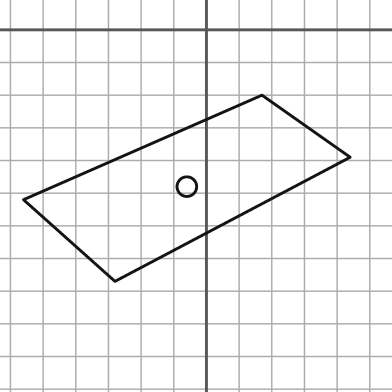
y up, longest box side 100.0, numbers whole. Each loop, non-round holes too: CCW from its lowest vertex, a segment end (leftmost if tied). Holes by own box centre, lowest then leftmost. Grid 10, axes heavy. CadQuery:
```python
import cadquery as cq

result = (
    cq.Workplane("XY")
    .moveTo(-28.0, -77.0)
    .lineTo(44.0, -39.0)
    .lineTo(17.0, -20.0)
    .lineTo(-56.0, -52.0)
    .close()
    .moveTo(-6.0, -48.0)
    .circle(3.0)
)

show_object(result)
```